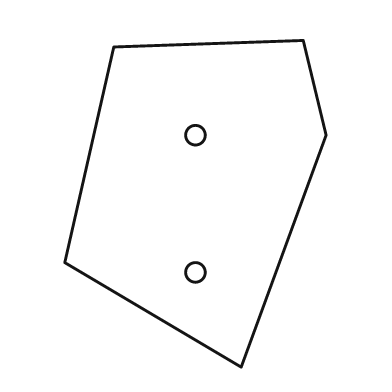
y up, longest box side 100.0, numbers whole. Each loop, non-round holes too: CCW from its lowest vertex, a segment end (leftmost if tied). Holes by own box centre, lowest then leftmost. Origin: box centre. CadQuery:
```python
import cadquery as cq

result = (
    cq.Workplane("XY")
    .moveTo(14.0, -50.0)
    .lineTo(40.0, 21.0)
    .lineTo(33.0, 50.0)
    .lineTo(-25.0, 48.0)
    .lineTo(-40.0, -18.0)
    .close()
    .moveTo(0.0, -21.0)
    .circle(3.0)
    .moveTo(0.0, 21.0)
    .circle(3.0)
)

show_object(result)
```